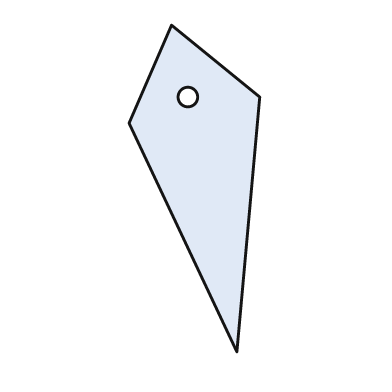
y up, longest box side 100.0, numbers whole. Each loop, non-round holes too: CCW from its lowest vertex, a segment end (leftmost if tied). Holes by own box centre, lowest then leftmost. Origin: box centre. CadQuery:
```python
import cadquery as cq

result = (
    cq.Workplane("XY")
    .moveTo(13.0, -50.0)
    .lineTo(20.0, 28.0)
    .lineTo(-7.0, 50.0)
    .lineTo(-20.0, 20.0)
    .close()
    .moveTo(-2.0, 28.0)
    .circle(3.0)
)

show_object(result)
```